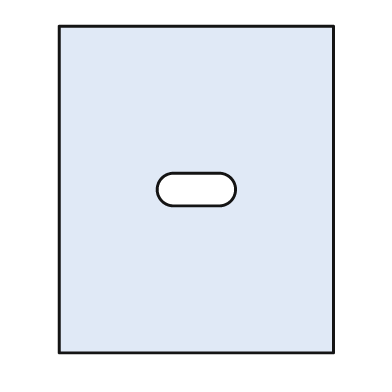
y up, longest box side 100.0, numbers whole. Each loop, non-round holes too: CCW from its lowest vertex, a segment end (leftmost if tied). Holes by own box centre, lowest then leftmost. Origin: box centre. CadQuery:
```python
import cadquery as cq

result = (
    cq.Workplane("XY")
    .moveTo(-42.0, -50.0)
    .lineTo(42.0, -50.0)
    .lineTo(42.0, 50.0)
    .lineTo(-42.0, 50.0)
    .close()
    .moveTo(-7.0, -5.0)
    .lineTo(7.0, -5.0)
    .threePointArc((12.0, 0.0), (7.0, 5.0))
    .lineTo(-7.0, 5.0)
    .threePointArc((-12.0, 0.0), (-7.0, -5.0))
    .close()
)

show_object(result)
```